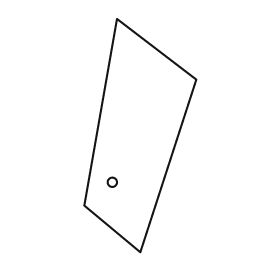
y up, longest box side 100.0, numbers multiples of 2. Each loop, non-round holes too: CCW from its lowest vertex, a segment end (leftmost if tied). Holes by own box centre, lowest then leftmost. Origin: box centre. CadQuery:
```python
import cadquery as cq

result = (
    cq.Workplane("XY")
    .moveTo(0.0, -50.0)
    .lineTo(24.0, 24.0)
    .lineTo(-10.0, 50.0)
    .lineTo(-24.0, -30.0)
    .close()
    .moveTo(-12.0, -20.0)
    .circle(2.0)
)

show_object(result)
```